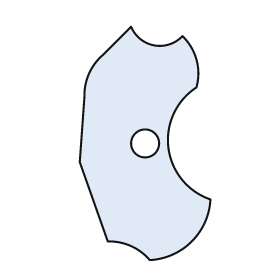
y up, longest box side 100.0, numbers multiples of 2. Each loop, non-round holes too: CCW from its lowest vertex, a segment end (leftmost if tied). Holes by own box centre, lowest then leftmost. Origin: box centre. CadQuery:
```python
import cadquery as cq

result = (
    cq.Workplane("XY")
    .moveTo(2.0, -50.0)
    .threePointArc((20.0, -42.0), (28.0, -24.0))
    .threePointArc((10.0, -2.0), (22.0, 24.0))
    .threePointArc((22.0, 36.0), (16.0, 46.0))
    .threePointArc((4.0, 42.0), (-6.0, 50.0))
    .lineTo(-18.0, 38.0)
    .threePointArc((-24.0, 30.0), (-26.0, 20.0))
    .lineTo(-28.0, -8.0)
    .lineTo(-16.0, -42.0)
    .threePointArc((-6.0, -44.0), (2.0, -50.0))
    .close()
    .moveTo(0.0, 0.0)
    .circle(6.0)
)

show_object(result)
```